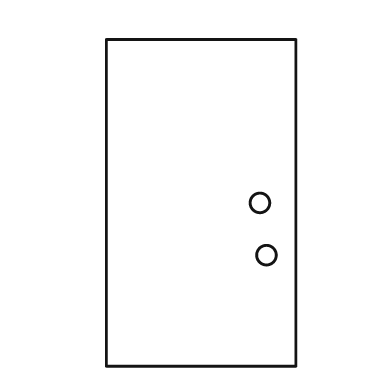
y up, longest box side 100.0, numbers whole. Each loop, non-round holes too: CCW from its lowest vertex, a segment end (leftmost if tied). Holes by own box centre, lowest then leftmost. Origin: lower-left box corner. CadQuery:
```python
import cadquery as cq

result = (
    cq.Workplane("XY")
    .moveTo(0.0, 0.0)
    .lineTo(58.0, 0.0)
    .lineTo(58.0, 100.0)
    .lineTo(0.0, 100.0)
    .close()
    .moveTo(49.0, 34.0)
    .circle(3.0)
    .moveTo(47.0, 50.0)
    .circle(3.0)
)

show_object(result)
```